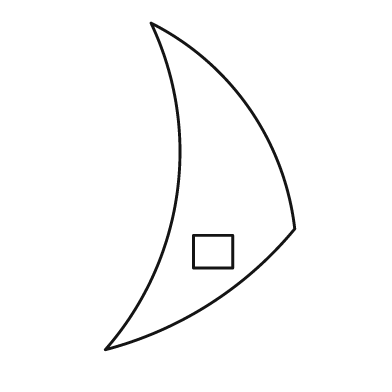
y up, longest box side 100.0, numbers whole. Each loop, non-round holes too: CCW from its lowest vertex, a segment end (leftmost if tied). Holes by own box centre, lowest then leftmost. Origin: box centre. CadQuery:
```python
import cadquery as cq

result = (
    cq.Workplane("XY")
    .moveTo(-29.0, -50.0)
    .threePointArc((3.0, -36.0), (29.0, -13.0))
    .threePointArc((15.0, 24.0), (-15.0, 50.0))
    .threePointArc((-7.0, -2.0), (-29.0, -50.0))
    .close()
    .moveTo(-2.0, -25.0)
    .lineTo(10.0, -25.0)
    .lineTo(10.0, -15.0)
    .lineTo(-2.0, -15.0)
    .close()
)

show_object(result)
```